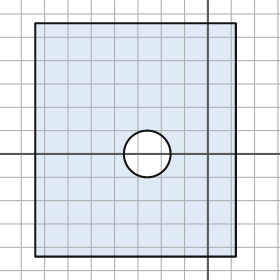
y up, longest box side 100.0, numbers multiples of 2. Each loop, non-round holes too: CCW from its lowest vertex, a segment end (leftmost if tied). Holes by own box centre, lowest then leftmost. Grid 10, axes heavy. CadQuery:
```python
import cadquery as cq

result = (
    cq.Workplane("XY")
    .moveTo(-74.0, -44.0)
    .lineTo(12.0, -44.0)
    .lineTo(12.0, 56.0)
    .lineTo(-74.0, 56.0)
    .close()
    .moveTo(-26.0, 0.0)
    .circle(10.0)
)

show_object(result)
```